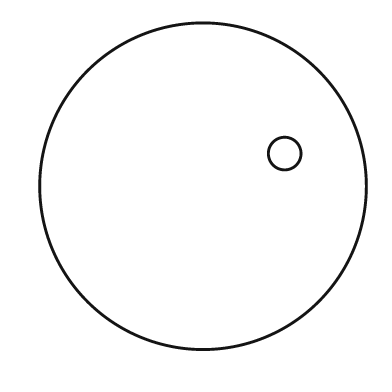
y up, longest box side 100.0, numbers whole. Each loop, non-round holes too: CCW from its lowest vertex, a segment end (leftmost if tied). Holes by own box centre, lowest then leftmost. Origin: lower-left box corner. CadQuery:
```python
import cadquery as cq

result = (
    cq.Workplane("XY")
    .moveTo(50.0, 50.0)
    .circle(50.0)
    .moveTo(75.0, 60.0)
    .circle(5.0)
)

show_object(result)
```